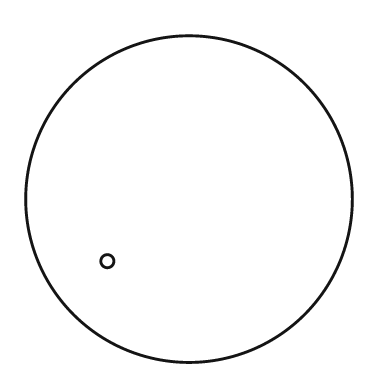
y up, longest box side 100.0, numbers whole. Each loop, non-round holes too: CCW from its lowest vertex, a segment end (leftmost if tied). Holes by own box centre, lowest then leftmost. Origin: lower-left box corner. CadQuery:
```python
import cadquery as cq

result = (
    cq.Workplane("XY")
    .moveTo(50.0, 50.0)
    .circle(50.0)
    .moveTo(25.0, 31.0)
    .circle(2.0)
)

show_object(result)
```